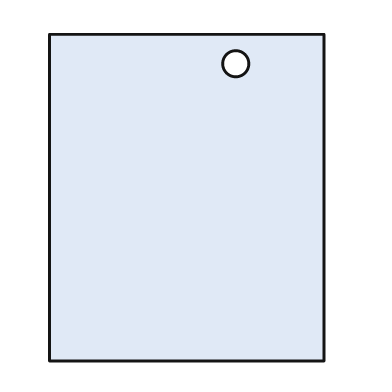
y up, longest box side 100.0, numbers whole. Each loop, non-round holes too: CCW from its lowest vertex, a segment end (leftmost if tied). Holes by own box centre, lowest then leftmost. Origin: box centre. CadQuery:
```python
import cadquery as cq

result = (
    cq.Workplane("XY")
    .moveTo(-42.0, -50.0)
    .lineTo(42.0, -50.0)
    .lineTo(42.0, 50.0)
    .lineTo(-42.0, 50.0)
    .close()
    .moveTo(15.0, 41.0)
    .circle(4.0)
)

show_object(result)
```